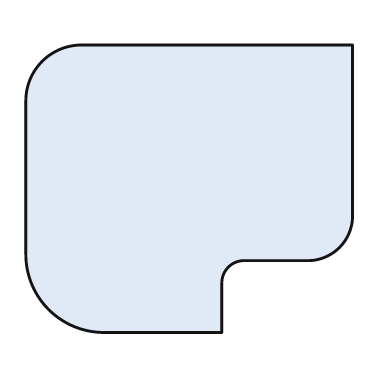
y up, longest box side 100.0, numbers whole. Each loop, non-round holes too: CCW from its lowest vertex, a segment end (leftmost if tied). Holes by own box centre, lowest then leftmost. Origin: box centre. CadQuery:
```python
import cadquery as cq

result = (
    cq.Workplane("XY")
    .moveTo(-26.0, -44.0)
    .lineTo(10.0, -44.0)
    .lineTo(10.0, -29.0)
    .threePointArc((12.0, -24.0), (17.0, -22.0))
    .lineTo(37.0, -22.0)
    .threePointArc((46.0, -18.0), (50.0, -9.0))
    .lineTo(50.0, 44.0)
    .lineTo(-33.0, 44.0)
    .threePointArc((-45.0, 39.0), (-50.0, 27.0))
    .lineTo(-50.0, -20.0)
    .threePointArc((-43.0, -37.0), (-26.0, -44.0))
    .close()
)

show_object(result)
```